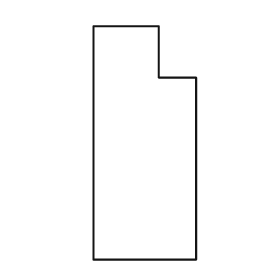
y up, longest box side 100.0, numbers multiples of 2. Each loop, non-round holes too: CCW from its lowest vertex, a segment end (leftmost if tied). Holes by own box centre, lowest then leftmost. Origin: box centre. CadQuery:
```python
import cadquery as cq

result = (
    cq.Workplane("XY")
    .moveTo(-22.0, -50.0)
    .lineTo(22.0, -50.0)
    .lineTo(22.0, 28.0)
    .lineTo(6.0, 28.0)
    .lineTo(6.0, 50.0)
    .lineTo(-22.0, 50.0)
    .close()
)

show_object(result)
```